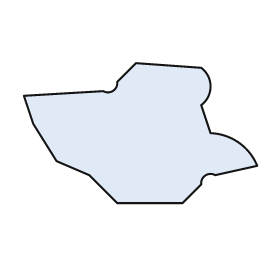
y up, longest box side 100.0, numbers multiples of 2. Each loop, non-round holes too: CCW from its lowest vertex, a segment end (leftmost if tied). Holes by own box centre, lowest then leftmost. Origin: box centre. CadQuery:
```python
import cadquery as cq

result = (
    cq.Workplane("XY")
    .moveTo(-10.0, -30.0)
    .lineTo(18.0, -30.0)
    .lineTo(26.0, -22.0)
    .threePointArc((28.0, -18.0), (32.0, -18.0))
    .lineTo(50.0, -14.0)
    .threePointArc((42.0, -4.0), (30.0, 0.0))
    .lineTo(26.0, 12.0)
    .threePointArc((30.0, 20.0), (26.0, 28.0))
    .lineTo(-2.0, 30.0)
    .lineTo(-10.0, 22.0)
    .threePointArc((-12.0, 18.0), (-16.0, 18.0))
    .lineTo(-50.0, 16.0)
    .lineTo(-46.0, 4.0)
    .lineTo(-36.0, -12.0)
    .lineTo(-22.0, -18.0)
    .close()
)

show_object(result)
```